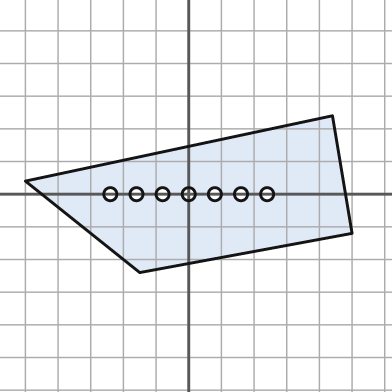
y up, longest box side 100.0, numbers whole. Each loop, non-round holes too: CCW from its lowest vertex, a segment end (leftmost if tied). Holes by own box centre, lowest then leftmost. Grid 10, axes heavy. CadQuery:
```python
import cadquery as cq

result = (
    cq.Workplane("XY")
    .moveTo(-15.0, -24.0)
    .lineTo(50.0, -12.0)
    .lineTo(44.0, 24.0)
    .lineTo(-50.0, 4.0)
    .close()
    .moveTo(-24.0, 0.0)
    .circle(2.0)
    .moveTo(-16.0, 0.0)
    .circle(2.0)
    .moveTo(-8.0, 0.0)
    .circle(2.0)
    .moveTo(0.0, 0.0)
    .circle(2.0)
    .moveTo(8.0, 0.0)
    .circle(2.0)
    .moveTo(16.0, 0.0)
    .circle(2.0)
    .moveTo(24.0, 0.0)
    .circle(2.0)
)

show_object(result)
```